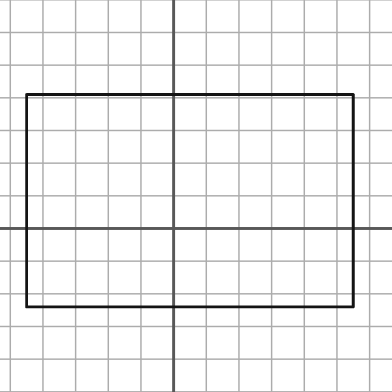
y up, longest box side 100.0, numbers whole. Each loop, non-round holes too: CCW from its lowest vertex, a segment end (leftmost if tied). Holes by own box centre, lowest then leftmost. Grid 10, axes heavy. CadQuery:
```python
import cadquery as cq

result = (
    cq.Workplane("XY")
    .moveTo(-45.0, -24.0)
    .lineTo(55.0, -24.0)
    .lineTo(55.0, 41.0)
    .lineTo(-45.0, 41.0)
    .close()
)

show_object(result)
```